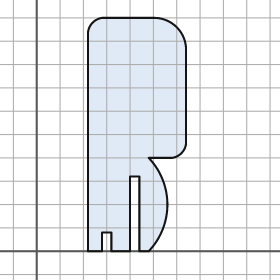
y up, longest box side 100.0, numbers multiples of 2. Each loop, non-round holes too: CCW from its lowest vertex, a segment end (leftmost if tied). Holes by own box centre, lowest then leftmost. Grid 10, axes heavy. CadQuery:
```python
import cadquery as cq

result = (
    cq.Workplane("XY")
    .moveTo(22.0, 0.0)
    .lineTo(28.0, 0.0)
    .lineTo(28.0, 8.0)
    .lineTo(32.0, 8.0)
    .lineTo(32.0, 0.0)
    .lineTo(40.0, 0.0)
    .lineTo(40.0, 32.0)
    .lineTo(44.0, 32.0)
    .lineTo(44.0, 0.0)
    .lineTo(48.0, 0.0)
    .threePointArc((56.0, 20.0), (48.0, 40.0))
    .lineTo(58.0, 40.0)
    .threePointArc((62.0, 42.0), (64.0, 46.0))
    .lineTo(64.0, 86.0)
    .threePointArc((60.0, 96.0), (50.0, 100.0))
    .lineTo(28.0, 100.0)
    .threePointArc((24.0, 98.0), (22.0, 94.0))
    .close()
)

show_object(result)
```